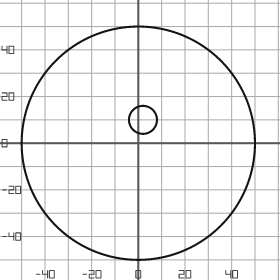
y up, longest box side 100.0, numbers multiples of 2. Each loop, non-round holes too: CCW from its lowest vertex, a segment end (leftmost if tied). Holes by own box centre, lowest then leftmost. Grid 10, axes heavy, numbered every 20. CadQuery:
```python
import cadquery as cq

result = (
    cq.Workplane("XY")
    .moveTo(0.0, 0.0)
    .circle(50.0)
    .moveTo(2.0, 10.0)
    .circle(6.0)
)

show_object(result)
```